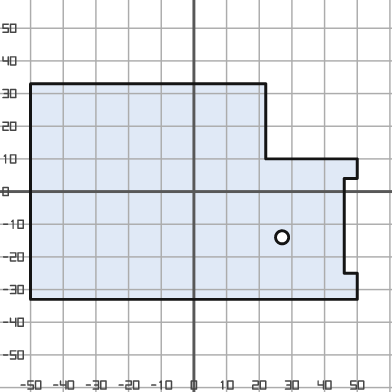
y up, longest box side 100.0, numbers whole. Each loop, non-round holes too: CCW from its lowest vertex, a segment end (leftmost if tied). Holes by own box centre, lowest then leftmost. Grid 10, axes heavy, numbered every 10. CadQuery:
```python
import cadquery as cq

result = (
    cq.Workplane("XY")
    .moveTo(-50.0, -33.0)
    .lineTo(50.0, -33.0)
    .lineTo(50.0, -25.0)
    .lineTo(46.0, -25.0)
    .lineTo(46.0, 4.0)
    .lineTo(50.0, 4.0)
    .lineTo(50.0, 10.0)
    .lineTo(22.0, 10.0)
    .lineTo(22.0, 33.0)
    .lineTo(-50.0, 33.0)
    .close()
    .moveTo(27.0, -14.0)
    .circle(2.0)
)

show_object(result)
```